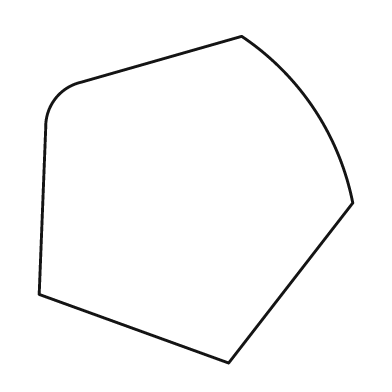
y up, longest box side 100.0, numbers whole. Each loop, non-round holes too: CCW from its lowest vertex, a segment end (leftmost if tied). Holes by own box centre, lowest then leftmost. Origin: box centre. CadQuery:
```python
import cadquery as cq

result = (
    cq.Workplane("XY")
    .moveTo(10.0, -50.0)
    .lineTo(48.0, -1.0)
    .threePointArc((36.0, 28.0), (14.0, 50.0))
    .lineTo(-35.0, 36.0)
    .threePointArc((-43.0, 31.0), (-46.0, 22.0))
    .lineTo(-48.0, -29.0)
    .close()
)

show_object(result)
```